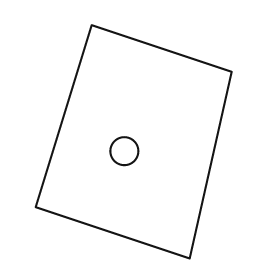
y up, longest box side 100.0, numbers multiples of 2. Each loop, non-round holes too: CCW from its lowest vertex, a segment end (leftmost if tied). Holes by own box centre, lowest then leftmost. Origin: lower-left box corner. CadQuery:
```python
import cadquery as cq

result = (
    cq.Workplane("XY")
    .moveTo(66.0, 0.0)
    .lineTo(84.0, 80.0)
    .lineTo(24.0, 100.0)
    .lineTo(0.0, 22.0)
    .close()
    .moveTo(38.0, 46.0)
    .circle(6.0)
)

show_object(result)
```